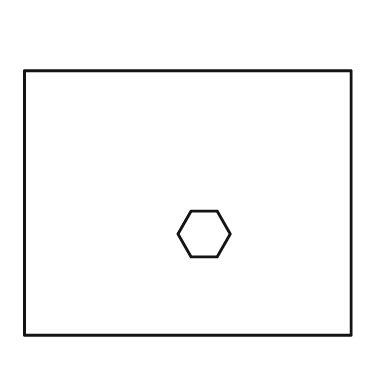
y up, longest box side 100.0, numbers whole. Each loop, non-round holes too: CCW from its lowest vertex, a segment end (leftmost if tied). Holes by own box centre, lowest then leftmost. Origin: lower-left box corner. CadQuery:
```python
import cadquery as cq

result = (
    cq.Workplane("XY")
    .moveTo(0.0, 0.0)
    .lineTo(100.0, 0.0)
    .lineTo(100.0, 81.0)
    .lineTo(0.0, 81.0)
    .close()
    .moveTo(51.0, 24.0)
    .lineTo(59.0, 24.0)
    .lineTo(63.0, 31.0)
    .lineTo(59.0, 38.0)
    .lineTo(51.0, 38.0)
    .lineTo(47.0, 31.0)
    .close()
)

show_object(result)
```